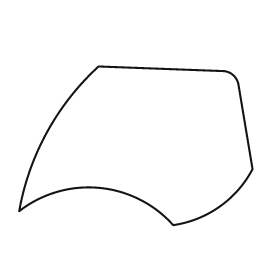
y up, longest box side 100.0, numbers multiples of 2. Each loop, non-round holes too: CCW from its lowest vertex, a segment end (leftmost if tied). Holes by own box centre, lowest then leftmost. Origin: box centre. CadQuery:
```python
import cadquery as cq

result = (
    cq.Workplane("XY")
    .moveTo(16.0, -34.0)
    .threePointArc((36.0, -26.0), (50.0, -10.0))
    .lineTo(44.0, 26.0)
    .threePointArc((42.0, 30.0), (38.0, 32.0))
    .lineTo(-16.0, 34.0)
    .threePointArc((-38.0, 6.0), (-50.0, -28.0))
    .threePointArc((-16.0, -18.0), (16.0, -34.0))
    .close()
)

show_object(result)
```